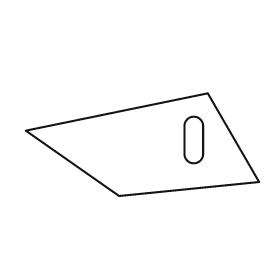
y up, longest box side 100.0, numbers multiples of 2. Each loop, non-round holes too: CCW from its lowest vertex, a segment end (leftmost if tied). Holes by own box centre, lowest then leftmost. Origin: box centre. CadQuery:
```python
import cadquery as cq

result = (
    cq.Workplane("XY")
    .moveTo(-10.0, -22.0)
    .lineTo(50.0, -16.0)
    .lineTo(28.0, 22.0)
    .lineTo(-50.0, 6.0)
    .close()
    .moveTo(18.0, -4.0)
    .threePointArc((22.0, -8.0), (26.0, -4.0))
    .lineTo(26.0, 8.0)
    .threePointArc((22.0, 12.0), (18.0, 8.0))
    .close()
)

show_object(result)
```